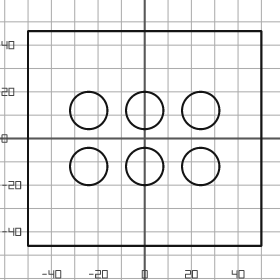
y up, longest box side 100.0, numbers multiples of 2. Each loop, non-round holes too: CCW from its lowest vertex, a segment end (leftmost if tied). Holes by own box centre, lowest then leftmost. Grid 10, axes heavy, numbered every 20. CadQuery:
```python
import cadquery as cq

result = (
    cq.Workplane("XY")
    .moveTo(-50.0, -46.0)
    .lineTo(50.0, -46.0)
    .lineTo(50.0, 46.0)
    .lineTo(-50.0, 46.0)
    .close()
    .moveTo(-24.0, -12.0)
    .circle(8.0)
    .moveTo(0.0, -12.0)
    .circle(8.0)
    .moveTo(24.0, -12.0)
    .circle(8.0)
    .moveTo(-24.0, 12.0)
    .circle(8.0)
    .moveTo(0.0, 12.0)
    .circle(8.0)
    .moveTo(24.0, 12.0)
    .circle(8.0)
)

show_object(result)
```